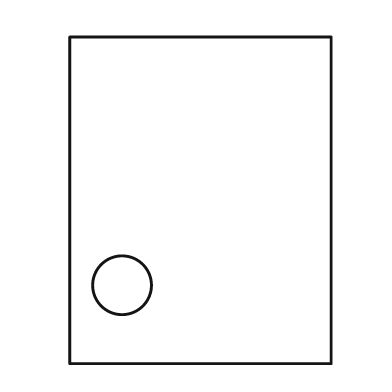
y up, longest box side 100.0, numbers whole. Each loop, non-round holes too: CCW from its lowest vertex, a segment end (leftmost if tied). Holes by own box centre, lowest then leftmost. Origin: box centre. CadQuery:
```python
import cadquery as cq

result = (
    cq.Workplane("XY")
    .moveTo(-40.0, -50.0)
    .lineTo(40.0, -50.0)
    .lineTo(40.0, 50.0)
    .lineTo(-40.0, 50.0)
    .close()
    .moveTo(-24.0, -26.0)
    .circle(9.0)
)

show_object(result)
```